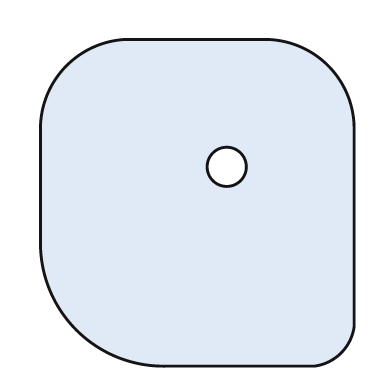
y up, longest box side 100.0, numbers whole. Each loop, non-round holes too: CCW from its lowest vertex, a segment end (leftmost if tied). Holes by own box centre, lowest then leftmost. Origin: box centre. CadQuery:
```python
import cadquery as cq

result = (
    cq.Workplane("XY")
    .moveTo(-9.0, -50.0)
    .lineTo(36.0, -50.0)
    .threePointArc((44.0, -46.0), (48.0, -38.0))
    .lineTo(48.0, 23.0)
    .threePointArc((40.0, 42.0), (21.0, 50.0))
    .lineTo(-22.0, 50.0)
    .threePointArc((-40.0, 42.0), (-48.0, 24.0))
    .lineTo(-48.0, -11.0)
    .threePointArc((-37.0, -39.0), (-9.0, -50.0))
    .close()
    .moveTo(9.0, 11.0)
    .circle(6.0)
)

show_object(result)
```